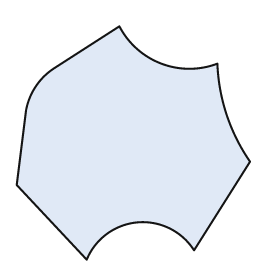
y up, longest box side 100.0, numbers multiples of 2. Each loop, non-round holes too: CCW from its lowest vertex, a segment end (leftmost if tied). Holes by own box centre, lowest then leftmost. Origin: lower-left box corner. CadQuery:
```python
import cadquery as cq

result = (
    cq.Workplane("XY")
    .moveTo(30.0, 0.0)
    .threePointArc((52.0, 16.0), (76.0, 4.0))
    .lineTo(100.0, 42.0)
    .threePointArc((90.0, 62.0), (86.0, 84.0))
    .threePointArc((62.0, 84.0), (44.0, 100.0))
    .lineTo(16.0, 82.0)
    .threePointArc((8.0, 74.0), (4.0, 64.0))
    .lineTo(0.0, 32.0)
    .close()
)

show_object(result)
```